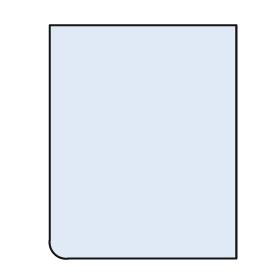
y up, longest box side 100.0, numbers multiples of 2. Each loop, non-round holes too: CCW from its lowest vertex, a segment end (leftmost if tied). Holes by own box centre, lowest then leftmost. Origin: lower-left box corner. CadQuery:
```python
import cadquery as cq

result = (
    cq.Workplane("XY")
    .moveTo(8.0, 0.0)
    .lineTo(80.0, 0.0)
    .lineTo(80.0, 100.0)
    .lineTo(0.0, 100.0)
    .lineTo(0.0, 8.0)
    .threePointArc((2.0, 2.0), (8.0, 0.0))
    .close()
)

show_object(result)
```